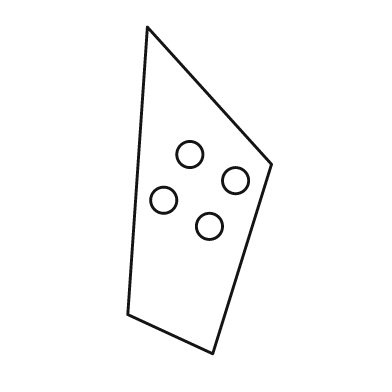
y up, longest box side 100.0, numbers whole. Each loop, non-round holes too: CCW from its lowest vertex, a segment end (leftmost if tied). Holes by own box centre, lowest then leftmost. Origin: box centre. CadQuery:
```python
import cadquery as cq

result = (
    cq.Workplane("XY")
    .moveTo(4.0, -50.0)
    .lineTo(22.0, 8.0)
    .lineTo(-16.0, 50.0)
    .lineTo(-22.0, -38.0)
    .close()
    .moveTo(3.0, -11.0)
    .circle(4.0)
    .moveTo(-11.0, -3.0)
    .circle(4.0)
    .moveTo(11.0, 3.0)
    .circle(4.0)
    .moveTo(-3.0, 11.0)
    .circle(4.0)
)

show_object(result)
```